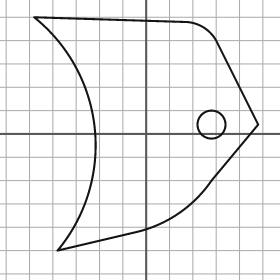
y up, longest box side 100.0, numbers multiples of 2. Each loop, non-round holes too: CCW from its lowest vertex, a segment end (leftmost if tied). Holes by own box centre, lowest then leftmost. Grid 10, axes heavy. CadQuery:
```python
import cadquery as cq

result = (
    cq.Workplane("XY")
    .moveTo(-38.0, -50.0)
    .lineTo(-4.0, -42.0)
    .threePointArc((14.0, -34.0), (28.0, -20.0))
    .lineTo(48.0, 4.0)
    .lineTo(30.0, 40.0)
    .threePointArc((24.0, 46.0), (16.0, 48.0))
    .lineTo(-48.0, 50.0)
    .threePointArc((-22.0, 2.0), (-38.0, -50.0))
    .close()
    .moveTo(28.0, 4.0)
    .circle(6.0)
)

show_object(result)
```